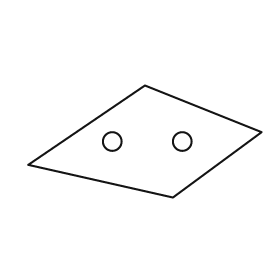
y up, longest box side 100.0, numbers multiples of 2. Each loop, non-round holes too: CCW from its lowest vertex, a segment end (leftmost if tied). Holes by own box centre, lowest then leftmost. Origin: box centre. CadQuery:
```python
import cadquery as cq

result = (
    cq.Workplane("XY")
    .moveTo(12.0, -24.0)
    .lineTo(50.0, 4.0)
    .lineTo(0.0, 24.0)
    .lineTo(-50.0, -10.0)
    .close()
    .moveTo(-14.0, 0.0)
    .circle(4.0)
    .moveTo(16.0, 0.0)
    .circle(4.0)
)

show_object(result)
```